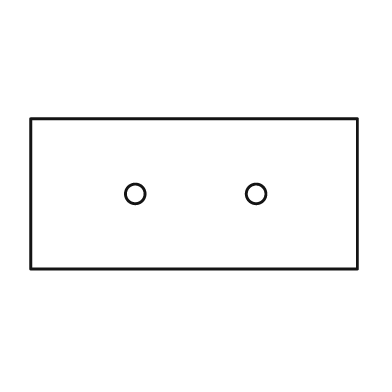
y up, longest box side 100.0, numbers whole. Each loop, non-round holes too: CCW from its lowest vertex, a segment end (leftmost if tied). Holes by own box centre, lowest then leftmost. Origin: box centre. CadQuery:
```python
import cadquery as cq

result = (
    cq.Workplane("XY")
    .moveTo(-50.0, -23.0)
    .lineTo(50.0, -23.0)
    .lineTo(50.0, 23.0)
    .lineTo(-50.0, 23.0)
    .close()
    .moveTo(-18.0, 0.0)
    .circle(3.0)
    .moveTo(19.0, 0.0)
    .circle(3.0)
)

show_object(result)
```